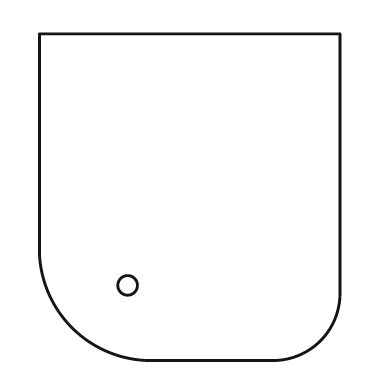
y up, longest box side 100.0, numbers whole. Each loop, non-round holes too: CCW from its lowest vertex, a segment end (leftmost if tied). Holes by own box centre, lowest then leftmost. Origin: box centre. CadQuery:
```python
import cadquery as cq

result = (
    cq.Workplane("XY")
    .moveTo(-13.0, -50.0)
    .lineTo(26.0, -50.0)
    .threePointArc((40.0, -44.0), (46.0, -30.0))
    .lineTo(46.0, 50.0)
    .lineTo(-46.0, 50.0)
    .lineTo(-46.0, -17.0)
    .threePointArc((-36.0, -40.0), (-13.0, -50.0))
    .close()
    .moveTo(-19.0, -27.0)
    .circle(3.0)
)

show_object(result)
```